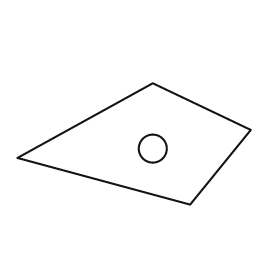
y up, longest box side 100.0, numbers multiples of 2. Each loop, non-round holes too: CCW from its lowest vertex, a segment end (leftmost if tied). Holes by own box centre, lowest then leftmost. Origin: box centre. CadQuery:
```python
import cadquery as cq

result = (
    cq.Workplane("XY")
    .moveTo(24.0, -26.0)
    .lineTo(50.0, 6.0)
    .lineTo(8.0, 26.0)
    .lineTo(-50.0, -6.0)
    .close()
    .moveTo(8.0, -2.0)
    .circle(6.0)
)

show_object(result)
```